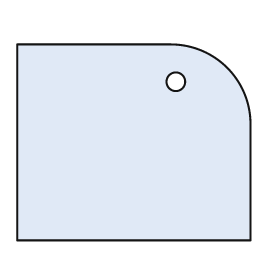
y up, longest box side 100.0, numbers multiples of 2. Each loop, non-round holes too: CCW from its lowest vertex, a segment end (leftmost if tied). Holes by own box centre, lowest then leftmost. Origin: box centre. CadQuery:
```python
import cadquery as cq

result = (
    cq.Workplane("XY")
    .moveTo(-50.0, -42.0)
    .lineTo(50.0, -42.0)
    .lineTo(50.0, 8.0)
    .threePointArc((40.0, 32.0), (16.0, 42.0))
    .lineTo(-50.0, 42.0)
    .close()
    .moveTo(18.0, 26.0)
    .circle(4.0)
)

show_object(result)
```